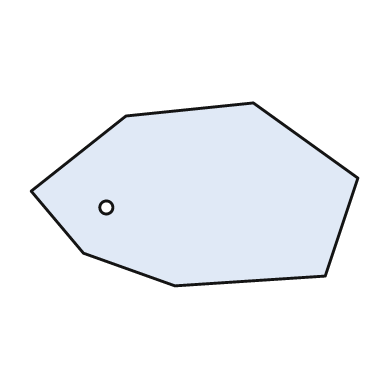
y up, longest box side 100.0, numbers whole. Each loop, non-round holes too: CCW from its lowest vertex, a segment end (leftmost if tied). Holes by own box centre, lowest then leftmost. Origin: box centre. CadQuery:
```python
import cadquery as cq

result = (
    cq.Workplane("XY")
    .moveTo(-6.0, -28.0)
    .lineTo(40.0, -25.0)
    .lineTo(50.0, 5.0)
    .lineTo(18.0, 28.0)
    .lineTo(-21.0, 24.0)
    .lineTo(-50.0, 1.0)
    .lineTo(-34.0, -18.0)
    .close()
    .moveTo(-27.0, -4.0)
    .circle(2.0)
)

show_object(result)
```